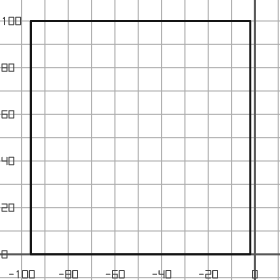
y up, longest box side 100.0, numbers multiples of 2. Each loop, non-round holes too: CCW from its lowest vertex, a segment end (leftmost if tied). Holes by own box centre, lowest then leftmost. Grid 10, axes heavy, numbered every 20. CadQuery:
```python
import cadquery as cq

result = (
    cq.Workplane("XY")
    .moveTo(-96.0, 0.0)
    .lineTo(-2.0, 0.0)
    .lineTo(-2.0, 100.0)
    .lineTo(-96.0, 100.0)
    .close()
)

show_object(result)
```